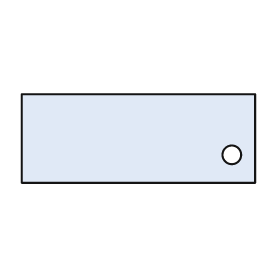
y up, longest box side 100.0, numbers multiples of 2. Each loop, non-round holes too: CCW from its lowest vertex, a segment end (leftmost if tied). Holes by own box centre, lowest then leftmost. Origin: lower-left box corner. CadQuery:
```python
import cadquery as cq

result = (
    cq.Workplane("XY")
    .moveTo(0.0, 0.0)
    .lineTo(100.0, 0.0)
    .lineTo(100.0, 38.0)
    .lineTo(0.0, 38.0)
    .close()
    .moveTo(90.0, 12.0)
    .circle(4.0)
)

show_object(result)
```